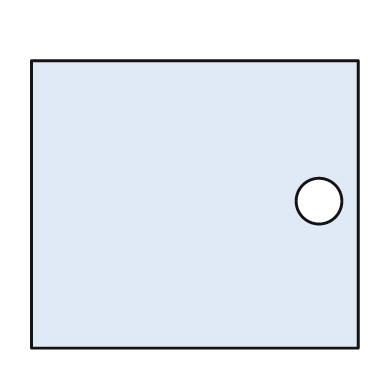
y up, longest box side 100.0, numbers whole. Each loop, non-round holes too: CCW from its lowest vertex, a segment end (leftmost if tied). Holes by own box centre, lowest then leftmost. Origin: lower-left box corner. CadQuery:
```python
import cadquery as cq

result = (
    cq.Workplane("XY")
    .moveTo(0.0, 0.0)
    .lineTo(100.0, 0.0)
    .lineTo(100.0, 88.0)
    .lineTo(0.0, 88.0)
    .close()
    .moveTo(88.0, 45.0)
    .circle(7.0)
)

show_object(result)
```